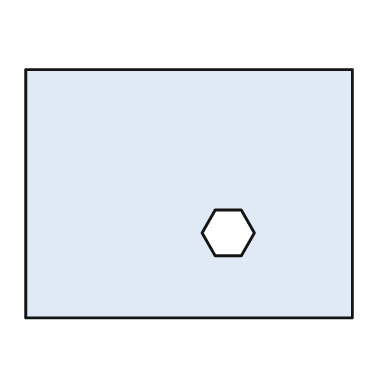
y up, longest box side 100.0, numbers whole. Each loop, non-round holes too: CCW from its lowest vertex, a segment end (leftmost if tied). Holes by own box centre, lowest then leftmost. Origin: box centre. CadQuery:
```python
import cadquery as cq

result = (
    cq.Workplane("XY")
    .moveTo(-50.0, -38.0)
    .lineTo(50.0, -38.0)
    .lineTo(50.0, 38.0)
    .lineTo(-50.0, 38.0)
    .close()
    .moveTo(8.0, -19.0)
    .lineTo(16.0, -19.0)
    .lineTo(20.0, -12.0)
    .lineTo(16.0, -5.0)
    .lineTo(8.0, -5.0)
    .lineTo(4.0, -12.0)
    .close()
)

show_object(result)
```